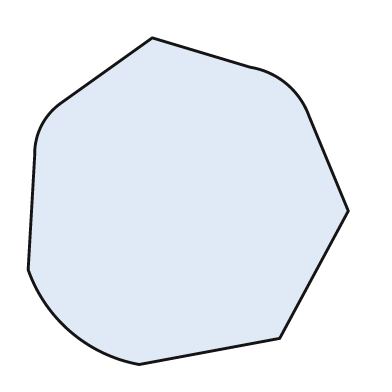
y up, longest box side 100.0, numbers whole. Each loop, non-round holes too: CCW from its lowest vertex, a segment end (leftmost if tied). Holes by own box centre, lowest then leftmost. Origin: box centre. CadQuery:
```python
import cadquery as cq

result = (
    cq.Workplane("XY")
    .moveTo(-15.0, -50.0)
    .lineTo(28.0, -42.0)
    .lineTo(49.0, -3.0)
    .lineTo(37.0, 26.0)
    .threePointArc((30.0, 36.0), (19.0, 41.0))
    .lineTo(-11.0, 50.0)
    .lineTo(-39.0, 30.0)
    .threePointArc((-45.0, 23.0), (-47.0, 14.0))
    .lineTo(-49.0, -21.0)
    .threePointArc((-36.0, -40.0), (-15.0, -50.0))
    .close()
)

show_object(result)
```